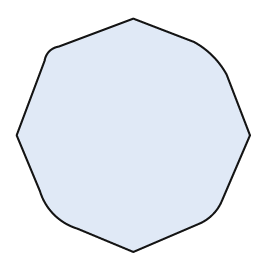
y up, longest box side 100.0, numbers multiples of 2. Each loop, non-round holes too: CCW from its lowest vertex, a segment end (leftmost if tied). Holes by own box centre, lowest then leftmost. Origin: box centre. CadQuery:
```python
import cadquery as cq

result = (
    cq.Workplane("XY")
    .moveTo(0.0, -50.0)
    .lineTo(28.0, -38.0)
    .threePointArc((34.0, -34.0), (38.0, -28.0))
    .lineTo(50.0, 0.0)
    .lineTo(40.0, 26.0)
    .threePointArc((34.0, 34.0), (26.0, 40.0))
    .lineTo(0.0, 50.0)
    .lineTo(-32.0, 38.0)
    .threePointArc((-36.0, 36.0), (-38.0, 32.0))
    .lineTo(-50.0, 0.0)
    .lineTo(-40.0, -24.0)
    .threePointArc((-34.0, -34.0), (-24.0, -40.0))
    .close()
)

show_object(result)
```